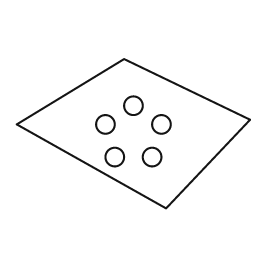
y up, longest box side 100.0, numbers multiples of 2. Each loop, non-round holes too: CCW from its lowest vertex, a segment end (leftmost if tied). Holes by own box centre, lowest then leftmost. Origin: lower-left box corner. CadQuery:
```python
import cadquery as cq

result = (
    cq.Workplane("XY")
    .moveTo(64.0, 0.0)
    .lineTo(100.0, 38.0)
    .lineTo(46.0, 64.0)
    .lineTo(0.0, 36.0)
    .close()
    .moveTo(42.0, 22.0)
    .circle(4.0)
    .moveTo(58.0, 22.0)
    .circle(4.0)
    .moveTo(38.0, 36.0)
    .circle(4.0)
    .moveTo(62.0, 36.0)
    .circle(4.0)
    .moveTo(50.0, 44.0)
    .circle(4.0)
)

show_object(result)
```